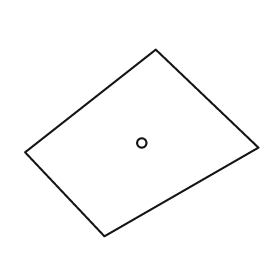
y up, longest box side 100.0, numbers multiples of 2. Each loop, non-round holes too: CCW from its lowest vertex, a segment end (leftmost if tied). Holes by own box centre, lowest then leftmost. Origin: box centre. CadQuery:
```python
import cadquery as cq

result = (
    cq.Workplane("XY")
    .moveTo(-16.0, -40.0)
    .lineTo(50.0, -2.0)
    .lineTo(6.0, 40.0)
    .lineTo(-50.0, -4.0)
    .close()
    .moveTo(0.0, 0.0)
    .circle(2.0)
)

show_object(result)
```